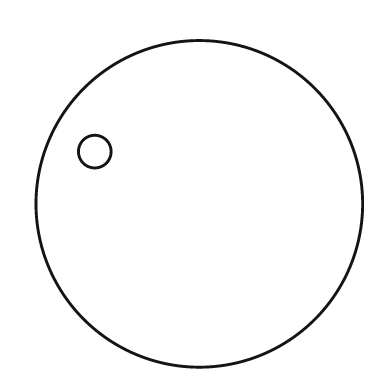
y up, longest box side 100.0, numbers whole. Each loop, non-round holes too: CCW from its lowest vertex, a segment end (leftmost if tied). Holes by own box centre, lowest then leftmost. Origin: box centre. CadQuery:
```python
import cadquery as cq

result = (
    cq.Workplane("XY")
    .moveTo(0.0, 0.0)
    .circle(50.0)
    .moveTo(-32.0, 16.0)
    .circle(5.0)
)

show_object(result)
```